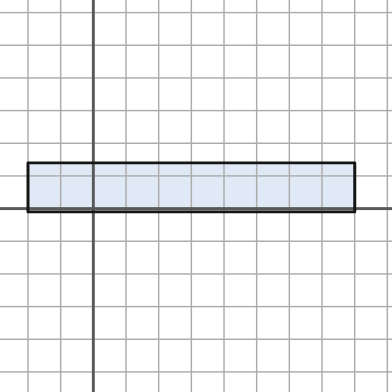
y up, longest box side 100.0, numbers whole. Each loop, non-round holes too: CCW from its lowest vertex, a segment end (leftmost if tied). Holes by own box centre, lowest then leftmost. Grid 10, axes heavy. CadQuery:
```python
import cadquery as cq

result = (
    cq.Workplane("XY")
    .moveTo(-20.0, -1.0)
    .lineTo(80.0, -1.0)
    .lineTo(80.0, 14.0)
    .lineTo(-20.0, 14.0)
    .close()
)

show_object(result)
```